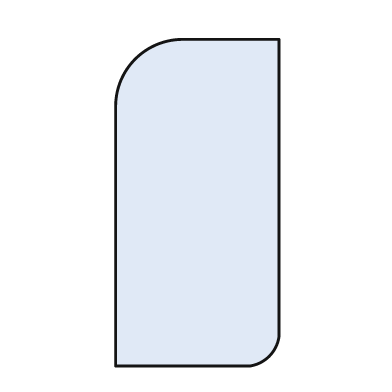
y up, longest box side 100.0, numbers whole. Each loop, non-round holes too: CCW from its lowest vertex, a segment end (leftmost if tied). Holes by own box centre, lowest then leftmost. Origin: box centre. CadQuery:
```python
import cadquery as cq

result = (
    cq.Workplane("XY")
    .moveTo(-25.0, -50.0)
    .lineTo(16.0, -50.0)
    .threePointArc((22.0, -47.0), (25.0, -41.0))
    .lineTo(25.0, 50.0)
    .lineTo(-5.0, 50.0)
    .threePointArc((-19.0, 44.0), (-25.0, 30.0))
    .close()
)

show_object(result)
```